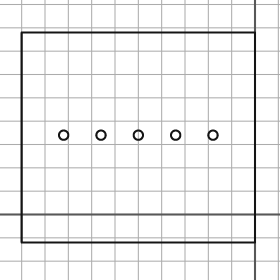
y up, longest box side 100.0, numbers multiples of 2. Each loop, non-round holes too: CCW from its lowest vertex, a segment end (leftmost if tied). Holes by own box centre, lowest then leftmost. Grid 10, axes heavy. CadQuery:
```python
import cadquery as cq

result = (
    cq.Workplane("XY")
    .moveTo(-100.0, -12.0)
    .lineTo(0.0, -12.0)
    .lineTo(0.0, 78.0)
    .lineTo(-100.0, 78.0)
    .close()
    .moveTo(-82.0, 34.0)
    .circle(2.0)
    .moveTo(-66.0, 34.0)
    .circle(2.0)
    .moveTo(-50.0, 34.0)
    .circle(2.0)
    .moveTo(-34.0, 34.0)
    .circle(2.0)
    .moveTo(-18.0, 34.0)
    .circle(2.0)
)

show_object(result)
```